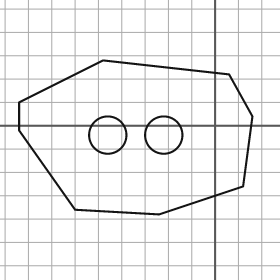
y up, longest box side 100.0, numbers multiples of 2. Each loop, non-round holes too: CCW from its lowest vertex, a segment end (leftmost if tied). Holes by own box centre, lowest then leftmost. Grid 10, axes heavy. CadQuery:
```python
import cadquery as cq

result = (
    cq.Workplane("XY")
    .moveTo(-24.0, -38.0)
    .lineTo(12.0, -26.0)
    .lineTo(16.0, 4.0)
    .lineTo(6.0, 22.0)
    .lineTo(-48.0, 28.0)
    .lineTo(-84.0, 10.0)
    .lineTo(-84.0, -2.0)
    .lineTo(-60.0, -36.0)
    .close()
    .moveTo(-46.0, -4.0)
    .circle(8.0)
    .moveTo(-22.0, -4.0)
    .circle(8.0)
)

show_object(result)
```